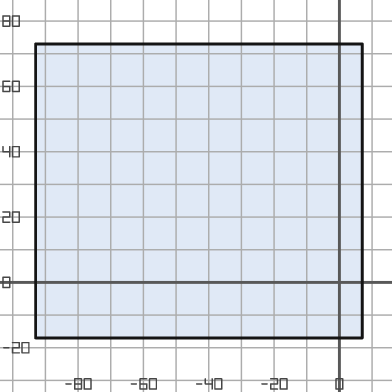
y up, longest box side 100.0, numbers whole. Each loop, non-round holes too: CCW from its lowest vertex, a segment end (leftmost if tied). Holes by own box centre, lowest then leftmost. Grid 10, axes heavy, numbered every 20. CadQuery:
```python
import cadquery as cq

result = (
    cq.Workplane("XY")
    .moveTo(-93.0, -17.0)
    .lineTo(7.0, -17.0)
    .lineTo(7.0, 73.0)
    .lineTo(-93.0, 73.0)
    .close()
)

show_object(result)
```